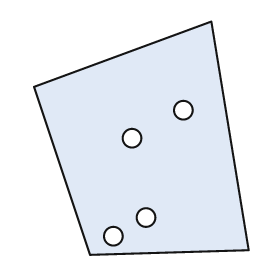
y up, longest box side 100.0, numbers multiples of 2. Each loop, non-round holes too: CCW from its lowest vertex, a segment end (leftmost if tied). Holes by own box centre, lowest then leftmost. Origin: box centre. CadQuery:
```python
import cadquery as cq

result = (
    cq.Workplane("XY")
    .moveTo(-22.0, -50.0)
    .lineTo(46.0, -48.0)
    .lineTo(30.0, 50.0)
    .lineTo(-46.0, 22.0)
    .close()
    .moveTo(-12.0, -42.0)
    .circle(4.0)
    .moveTo(2.0, -34.0)
    .circle(4.0)
    .moveTo(-4.0, 0.0)
    .circle(4.0)
    .moveTo(18.0, 12.0)
    .circle(4.0)
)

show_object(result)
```